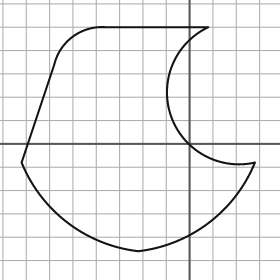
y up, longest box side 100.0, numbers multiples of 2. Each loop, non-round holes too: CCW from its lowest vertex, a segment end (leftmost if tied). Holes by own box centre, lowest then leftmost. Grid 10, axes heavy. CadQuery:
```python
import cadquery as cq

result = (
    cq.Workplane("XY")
    .moveTo(-22.0, -46.0)
    .threePointArc((8.0, -34.0), (28.0, -8.0))
    .threePointArc((-8.0, 12.0), (8.0, 50.0))
    .lineTo(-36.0, 50.0)
    .threePointArc((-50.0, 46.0), (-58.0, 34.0))
    .lineTo(-72.0, -8.0)
    .threePointArc((-52.0, -34.0), (-22.0, -46.0))
    .close()
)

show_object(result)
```